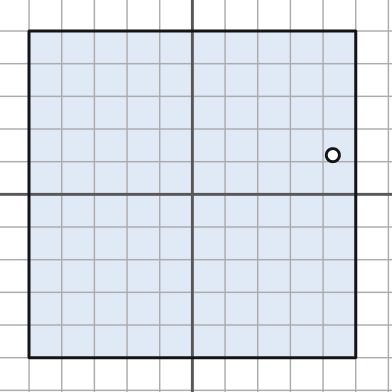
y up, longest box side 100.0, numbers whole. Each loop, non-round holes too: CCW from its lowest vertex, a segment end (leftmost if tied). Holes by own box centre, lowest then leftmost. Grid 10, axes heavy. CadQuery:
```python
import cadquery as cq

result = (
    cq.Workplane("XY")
    .moveTo(-50.0, -50.0)
    .lineTo(50.0, -50.0)
    .lineTo(50.0, 50.0)
    .lineTo(-50.0, 50.0)
    .close()
    .moveTo(43.0, 12.0)
    .circle(2.0)
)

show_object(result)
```